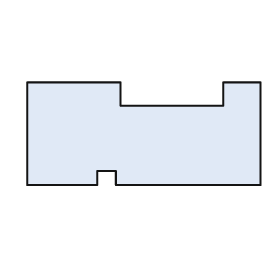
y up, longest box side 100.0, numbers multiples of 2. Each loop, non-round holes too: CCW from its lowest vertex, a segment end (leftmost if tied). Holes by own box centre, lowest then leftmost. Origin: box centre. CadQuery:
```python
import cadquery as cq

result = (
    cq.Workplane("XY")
    .moveTo(-50.0, -22.0)
    .lineTo(-20.0, -22.0)
    .lineTo(-20.0, -16.0)
    .lineTo(-12.0, -16.0)
    .lineTo(-12.0, -22.0)
    .lineTo(50.0, -22.0)
    .lineTo(50.0, 22.0)
    .lineTo(34.0, 22.0)
    .lineTo(34.0, 12.0)
    .lineTo(-10.0, 12.0)
    .lineTo(-10.0, 22.0)
    .lineTo(-50.0, 22.0)
    .close()
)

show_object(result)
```